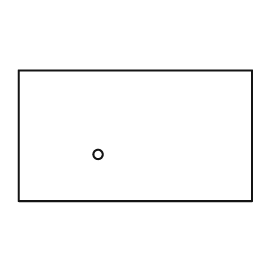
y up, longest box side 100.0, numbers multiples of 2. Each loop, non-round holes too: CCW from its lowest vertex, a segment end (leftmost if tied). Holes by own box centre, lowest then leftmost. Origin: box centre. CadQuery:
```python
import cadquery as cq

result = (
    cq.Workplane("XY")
    .moveTo(-50.0, -28.0)
    .lineTo(50.0, -28.0)
    .lineTo(50.0, 28.0)
    .lineTo(-50.0, 28.0)
    .close()
    .moveTo(-16.0, -8.0)
    .circle(2.0)
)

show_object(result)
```